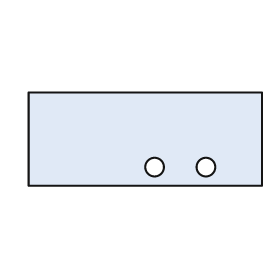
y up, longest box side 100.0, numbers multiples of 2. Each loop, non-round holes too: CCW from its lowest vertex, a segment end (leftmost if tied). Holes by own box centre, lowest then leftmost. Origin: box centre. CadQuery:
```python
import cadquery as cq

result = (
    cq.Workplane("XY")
    .moveTo(-50.0, -20.0)
    .lineTo(50.0, -20.0)
    .lineTo(50.0, 20.0)
    .lineTo(-50.0, 20.0)
    .close()
    .moveTo(4.0, -12.0)
    .circle(4.0)
    .moveTo(26.0, -12.0)
    .circle(4.0)
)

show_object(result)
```